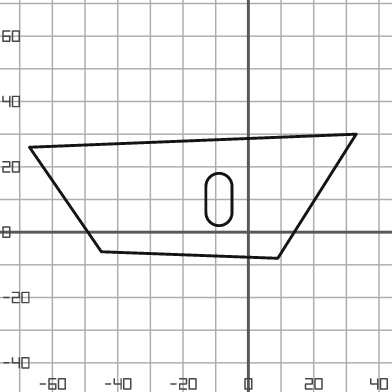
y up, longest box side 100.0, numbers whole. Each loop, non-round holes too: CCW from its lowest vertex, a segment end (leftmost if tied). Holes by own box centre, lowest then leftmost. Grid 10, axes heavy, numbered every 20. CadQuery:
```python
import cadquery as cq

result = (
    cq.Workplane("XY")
    .moveTo(9.0, -8.0)
    .lineTo(33.0, 30.0)
    .lineTo(-67.0, 26.0)
    .lineTo(-45.0, -6.0)
    .close()
    .moveTo(-13.0, 6.0)
    .threePointArc((-9.0, 2.0), (-5.0, 6.0))
    .lineTo(-5.0, 14.0)
    .threePointArc((-9.0, 18.0), (-13.0, 14.0))
    .close()
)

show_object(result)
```